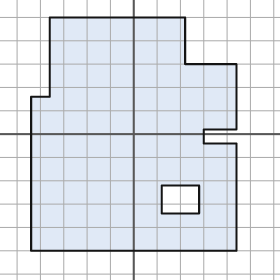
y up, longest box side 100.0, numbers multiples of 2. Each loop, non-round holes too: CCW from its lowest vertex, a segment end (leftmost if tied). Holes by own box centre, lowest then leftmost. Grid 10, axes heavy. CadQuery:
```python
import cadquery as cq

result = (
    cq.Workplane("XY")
    .moveTo(-44.0, -50.0)
    .lineTo(44.0, -50.0)
    .lineTo(44.0, -4.0)
    .lineTo(30.0, -4.0)
    .lineTo(30.0, 2.0)
    .lineTo(44.0, 2.0)
    .lineTo(44.0, 30.0)
    .lineTo(22.0, 30.0)
    .lineTo(22.0, 50.0)
    .lineTo(-36.0, 50.0)
    .lineTo(-36.0, 16.0)
    .lineTo(-44.0, 16.0)
    .close()
    .moveTo(12.0, -34.0)
    .lineTo(28.0, -34.0)
    .lineTo(28.0, -22.0)
    .lineTo(12.0, -22.0)
    .close()
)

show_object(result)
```